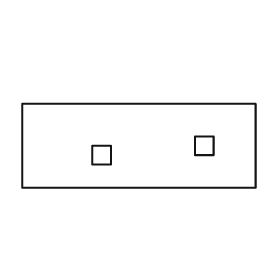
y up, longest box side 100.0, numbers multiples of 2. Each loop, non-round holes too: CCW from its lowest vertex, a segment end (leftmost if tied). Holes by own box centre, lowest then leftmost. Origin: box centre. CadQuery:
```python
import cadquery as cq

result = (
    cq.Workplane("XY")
    .moveTo(-50.0, -18.0)
    .lineTo(50.0, -18.0)
    .lineTo(50.0, 18.0)
    .lineTo(-50.0, 18.0)
    .close()
    .moveTo(-20.0, -8.0)
    .lineTo(-12.0, -8.0)
    .lineTo(-12.0, 0.0)
    .lineTo(-20.0, 0.0)
    .close()
    .moveTo(24.0, -4.0)
    .lineTo(32.0, -4.0)
    .lineTo(32.0, 4.0)
    .lineTo(24.0, 4.0)
    .close()
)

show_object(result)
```